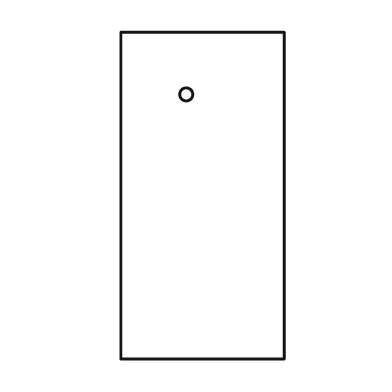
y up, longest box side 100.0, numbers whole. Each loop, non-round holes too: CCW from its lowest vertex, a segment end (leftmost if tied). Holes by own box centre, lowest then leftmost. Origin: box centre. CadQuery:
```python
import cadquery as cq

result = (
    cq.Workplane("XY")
    .moveTo(-25.0, -50.0)
    .lineTo(25.0, -50.0)
    .lineTo(25.0, 50.0)
    .lineTo(-25.0, 50.0)
    .close()
    .moveTo(-5.0, 31.0)
    .circle(2.0)
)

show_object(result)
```